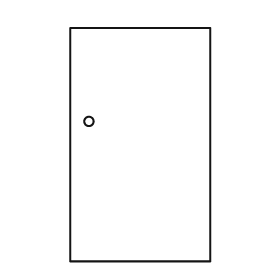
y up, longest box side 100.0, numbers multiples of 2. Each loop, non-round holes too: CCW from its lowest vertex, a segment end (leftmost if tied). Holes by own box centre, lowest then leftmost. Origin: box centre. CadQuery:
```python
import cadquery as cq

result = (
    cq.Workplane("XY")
    .moveTo(-30.0, -50.0)
    .lineTo(30.0, -50.0)
    .lineTo(30.0, 50.0)
    .lineTo(-30.0, 50.0)
    .close()
    .moveTo(-22.0, 10.0)
    .circle(2.0)
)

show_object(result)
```